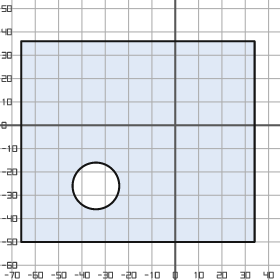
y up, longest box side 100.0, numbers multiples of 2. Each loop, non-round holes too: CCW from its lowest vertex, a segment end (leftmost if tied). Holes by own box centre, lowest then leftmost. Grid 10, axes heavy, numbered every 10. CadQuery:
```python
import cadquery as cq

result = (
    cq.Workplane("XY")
    .moveTo(-66.0, -50.0)
    .lineTo(34.0, -50.0)
    .lineTo(34.0, 36.0)
    .lineTo(-66.0, 36.0)
    .close()
    .moveTo(-34.0, -26.0)
    .circle(10.0)
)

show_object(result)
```